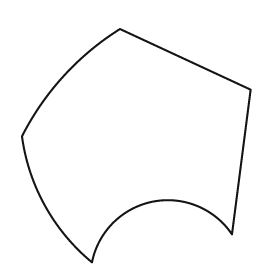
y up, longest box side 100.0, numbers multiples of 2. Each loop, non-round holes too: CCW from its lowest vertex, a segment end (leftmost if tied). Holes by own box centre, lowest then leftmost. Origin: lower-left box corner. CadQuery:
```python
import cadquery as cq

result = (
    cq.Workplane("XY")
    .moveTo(30.0, 0.0)
    .threePointArc((56.0, 26.0), (90.0, 12.0))
    .lineTo(98.0, 74.0)
    .lineTo(42.0, 100.0)
    .threePointArc((18.0, 80.0), (0.0, 54.0))
    .threePointArc((10.0, 24.0), (30.0, 0.0))
    .close()
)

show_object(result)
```